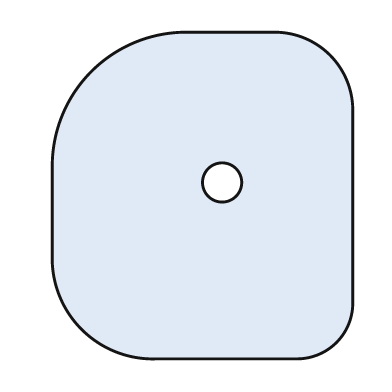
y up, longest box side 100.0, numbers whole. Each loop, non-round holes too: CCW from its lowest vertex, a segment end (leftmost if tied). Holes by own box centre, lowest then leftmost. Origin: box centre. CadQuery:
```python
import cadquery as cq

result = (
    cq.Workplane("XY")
    .moveTo(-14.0, -50.0)
    .lineTo(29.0, -50.0)
    .threePointArc((41.0, -45.0), (46.0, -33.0))
    .lineTo(46.0, 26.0)
    .threePointArc((39.0, 43.0), (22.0, 50.0))
    .lineTo(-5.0, 50.0)
    .threePointArc((-34.0, 38.0), (-46.0, 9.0))
    .lineTo(-46.0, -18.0)
    .threePointArc((-37.0, -41.0), (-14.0, -50.0))
    .close()
    .moveTo(6.0, 4.0)
    .circle(6.0)
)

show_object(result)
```